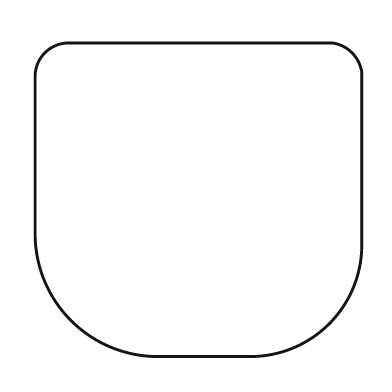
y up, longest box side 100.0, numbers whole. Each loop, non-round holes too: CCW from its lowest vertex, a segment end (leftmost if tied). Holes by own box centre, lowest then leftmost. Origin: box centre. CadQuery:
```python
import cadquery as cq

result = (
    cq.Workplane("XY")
    .moveTo(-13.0, -48.0)
    .lineTo(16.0, -48.0)
    .threePointArc((40.0, -38.0), (50.0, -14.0))
    .lineTo(50.0, 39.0)
    .threePointArc((47.0, 45.0), (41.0, 48.0))
    .lineTo(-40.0, 48.0)
    .threePointArc((-47.0, 45.0), (-50.0, 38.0))
    .lineTo(-50.0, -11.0)
    .threePointArc((-39.0, -37.0), (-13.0, -48.0))
    .close()
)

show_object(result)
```